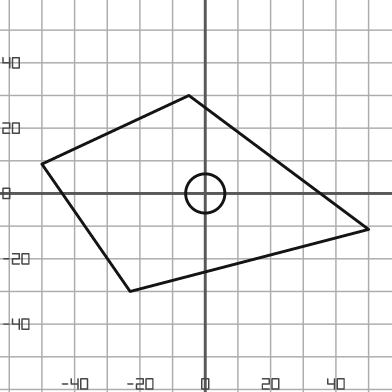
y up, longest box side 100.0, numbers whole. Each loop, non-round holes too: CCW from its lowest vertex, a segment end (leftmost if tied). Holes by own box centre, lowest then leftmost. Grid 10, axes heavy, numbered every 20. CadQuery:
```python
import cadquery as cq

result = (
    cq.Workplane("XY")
    .moveTo(-23.0, -30.0)
    .lineTo(50.0, -11.0)
    .lineTo(-5.0, 30.0)
    .lineTo(-50.0, 9.0)
    .close()
    .moveTo(0.0, 0.0)
    .circle(6.0)
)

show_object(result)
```